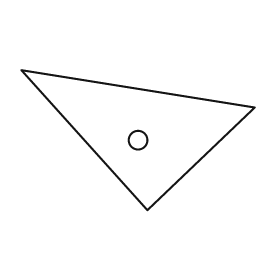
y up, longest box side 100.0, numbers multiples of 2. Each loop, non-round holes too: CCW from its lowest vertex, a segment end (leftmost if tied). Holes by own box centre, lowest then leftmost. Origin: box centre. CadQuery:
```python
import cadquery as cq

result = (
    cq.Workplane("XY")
    .moveTo(4.0, -30.0)
    .lineTo(50.0, 14.0)
    .lineTo(-50.0, 30.0)
    .close()
    .moveTo(0.0, 0.0)
    .circle(4.0)
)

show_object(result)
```